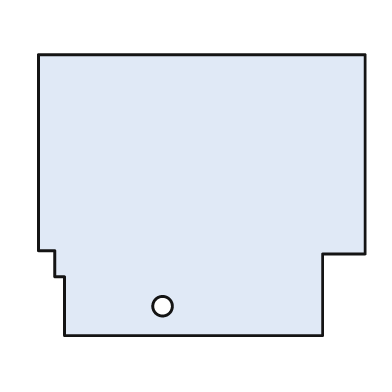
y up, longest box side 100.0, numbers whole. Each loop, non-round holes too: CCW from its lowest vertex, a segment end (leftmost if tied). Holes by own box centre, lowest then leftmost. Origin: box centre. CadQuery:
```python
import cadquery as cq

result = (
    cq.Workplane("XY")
    .moveTo(-42.0, -43.0)
    .lineTo(37.0, -43.0)
    .lineTo(37.0, -18.0)
    .lineTo(50.0, -18.0)
    .lineTo(50.0, 43.0)
    .lineTo(-50.0, 43.0)
    .lineTo(-50.0, -17.0)
    .lineTo(-45.0, -17.0)
    .lineTo(-45.0, -25.0)
    .lineTo(-42.0, -25.0)
    .close()
    .moveTo(-12.0, -34.0)
    .circle(3.0)
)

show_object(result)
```